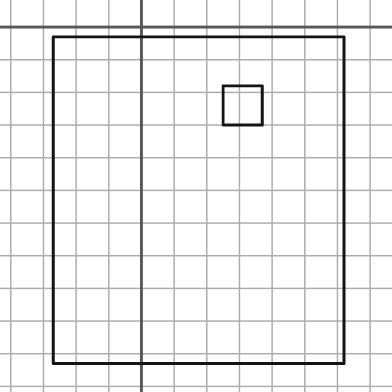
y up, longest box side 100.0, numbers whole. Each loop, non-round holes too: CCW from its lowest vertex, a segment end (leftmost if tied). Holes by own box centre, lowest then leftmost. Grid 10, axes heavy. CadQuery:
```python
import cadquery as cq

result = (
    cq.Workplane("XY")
    .moveTo(-27.0, -103.0)
    .lineTo(62.0, -103.0)
    .lineTo(62.0, -3.0)
    .lineTo(-27.0, -3.0)
    .close()
    .moveTo(25.0, -30.0)
    .lineTo(37.0, -30.0)
    .lineTo(37.0, -18.0)
    .lineTo(25.0, -18.0)
    .close()
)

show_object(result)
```